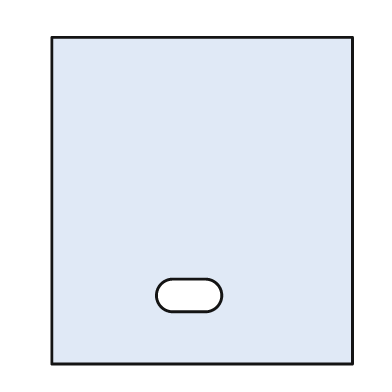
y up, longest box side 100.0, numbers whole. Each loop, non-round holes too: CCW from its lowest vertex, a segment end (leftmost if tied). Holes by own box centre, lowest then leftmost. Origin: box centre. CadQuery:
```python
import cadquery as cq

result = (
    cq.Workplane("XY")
    .moveTo(-46.0, -50.0)
    .lineTo(46.0, -50.0)
    .lineTo(46.0, 50.0)
    .lineTo(-46.0, 50.0)
    .close()
    .moveTo(-9.0, -34.0)
    .lineTo(1.0, -34.0)
    .threePointArc((6.0, -29.0), (1.0, -24.0))
    .lineTo(-9.0, -24.0)
    .threePointArc((-14.0, -29.0), (-9.0, -34.0))
    .close()
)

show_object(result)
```